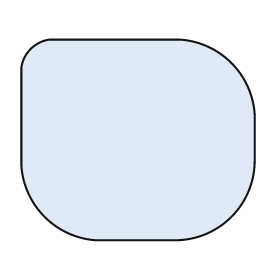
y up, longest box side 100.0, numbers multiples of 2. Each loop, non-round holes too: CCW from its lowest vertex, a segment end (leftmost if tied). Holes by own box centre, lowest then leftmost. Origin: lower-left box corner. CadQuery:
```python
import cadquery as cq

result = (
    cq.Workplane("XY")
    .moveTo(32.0, 0.0)
    .lineTo(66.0, 0.0)
    .threePointArc((90.0, 10.0), (100.0, 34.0))
    .lineTo(100.0, 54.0)
    .threePointArc((90.0, 76.0), (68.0, 86.0))
    .lineTo(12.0, 86.0)
    .threePointArc((4.0, 82.0), (0.0, 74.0))
    .lineTo(0.0, 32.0)
    .threePointArc((10.0, 10.0), (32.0, 0.0))
    .close()
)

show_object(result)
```